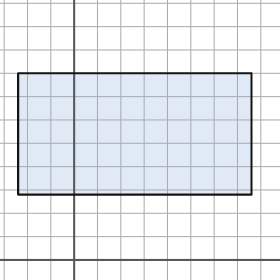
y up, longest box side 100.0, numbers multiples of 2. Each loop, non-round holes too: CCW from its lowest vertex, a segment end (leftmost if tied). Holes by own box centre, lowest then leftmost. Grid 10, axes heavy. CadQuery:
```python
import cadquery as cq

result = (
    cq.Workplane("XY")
    .moveTo(-24.0, 28.0)
    .lineTo(76.0, 28.0)
    .lineTo(76.0, 80.0)
    .lineTo(-24.0, 80.0)
    .close()
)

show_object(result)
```